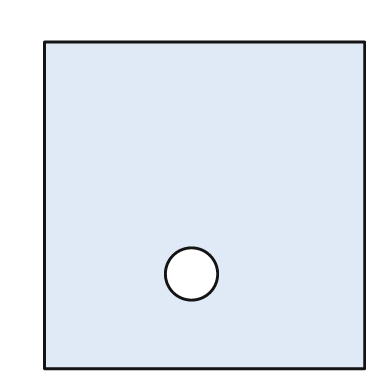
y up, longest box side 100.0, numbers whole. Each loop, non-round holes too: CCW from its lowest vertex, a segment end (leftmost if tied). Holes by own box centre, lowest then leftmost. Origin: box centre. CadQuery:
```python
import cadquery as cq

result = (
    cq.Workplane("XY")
    .moveTo(-49.0, -50.0)
    .lineTo(49.0, -50.0)
    .lineTo(49.0, 50.0)
    .lineTo(-49.0, 50.0)
    .close()
    .moveTo(-4.0, -21.0)
    .circle(8.0)
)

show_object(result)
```